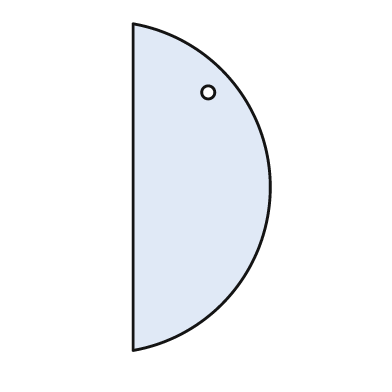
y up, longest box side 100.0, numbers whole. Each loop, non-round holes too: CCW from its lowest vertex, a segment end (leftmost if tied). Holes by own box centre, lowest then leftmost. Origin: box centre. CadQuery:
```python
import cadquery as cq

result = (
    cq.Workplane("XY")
    .moveTo(-21.0, -50.0)
    .threePointArc((21.0, 0.0), (-21.0, 50.0))
    .close()
    .moveTo(2.0, 29.0)
    .circle(2.0)
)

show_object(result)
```